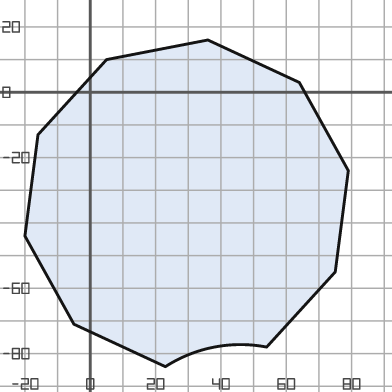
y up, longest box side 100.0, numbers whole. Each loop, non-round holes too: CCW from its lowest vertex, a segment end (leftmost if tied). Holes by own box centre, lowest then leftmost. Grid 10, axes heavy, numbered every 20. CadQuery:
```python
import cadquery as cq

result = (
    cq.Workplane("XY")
    .moveTo(23.0, -84.0)
    .threePointArc((38.0, -78.0), (54.0, -78.0))
    .lineTo(75.0, -55.0)
    .lineTo(79.0, -24.0)
    .lineTo(64.0, 3.0)
    .lineTo(36.0, 16.0)
    .lineTo(5.0, 10.0)
    .lineTo(-16.0, -13.0)
    .lineTo(-20.0, -44.0)
    .lineTo(-5.0, -71.0)
    .close()
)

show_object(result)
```